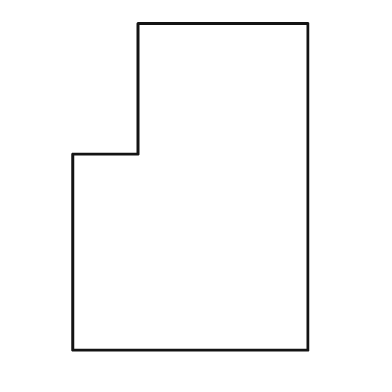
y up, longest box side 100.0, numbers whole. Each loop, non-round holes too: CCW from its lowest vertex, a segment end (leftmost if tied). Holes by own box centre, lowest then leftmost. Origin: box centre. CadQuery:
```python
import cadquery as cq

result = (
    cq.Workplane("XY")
    .moveTo(-36.0, -50.0)
    .lineTo(36.0, -50.0)
    .lineTo(36.0, 50.0)
    .lineTo(-16.0, 50.0)
    .lineTo(-16.0, 10.0)
    .lineTo(-36.0, 10.0)
    .close()
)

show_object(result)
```